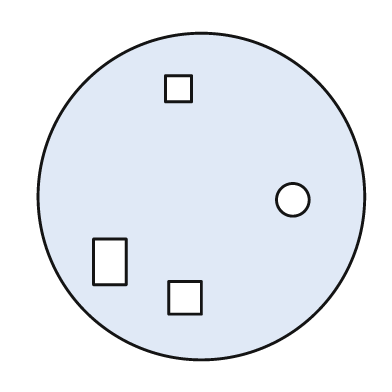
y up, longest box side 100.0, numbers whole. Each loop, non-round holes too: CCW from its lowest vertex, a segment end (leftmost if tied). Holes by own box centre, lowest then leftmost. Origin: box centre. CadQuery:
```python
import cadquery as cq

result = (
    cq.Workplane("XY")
    .moveTo(0.0, 0.0)
    .circle(50.0)
    .moveTo(-10.0, -36.0)
    .lineTo(0.0, -36.0)
    .lineTo(0.0, -26.0)
    .lineTo(-10.0, -26.0)
    .close()
    .moveTo(-33.0, -27.0)
    .lineTo(-23.0, -27.0)
    .lineTo(-23.0, -13.0)
    .lineTo(-33.0, -13.0)
    .close()
    .moveTo(28.0, -1.0)
    .circle(5.0)
    .moveTo(-11.0, 29.0)
    .lineTo(-3.0, 29.0)
    .lineTo(-3.0, 37.0)
    .lineTo(-11.0, 37.0)
    .close()
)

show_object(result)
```